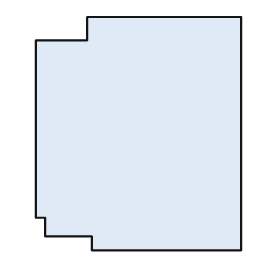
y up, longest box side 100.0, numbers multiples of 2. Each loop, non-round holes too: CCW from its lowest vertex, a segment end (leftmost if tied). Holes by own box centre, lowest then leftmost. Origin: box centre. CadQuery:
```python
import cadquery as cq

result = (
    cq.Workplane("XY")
    .moveTo(-20.0, -50.0)
    .lineTo(44.0, -50.0)
    .lineTo(44.0, 50.0)
    .lineTo(-22.0, 50.0)
    .lineTo(-22.0, 40.0)
    .lineTo(-44.0, 40.0)
    .lineTo(-44.0, -36.0)
    .lineTo(-40.0, -36.0)
    .lineTo(-40.0, -44.0)
    .lineTo(-20.0, -44.0)
    .close()
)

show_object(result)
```